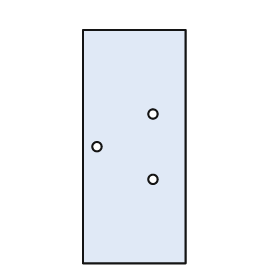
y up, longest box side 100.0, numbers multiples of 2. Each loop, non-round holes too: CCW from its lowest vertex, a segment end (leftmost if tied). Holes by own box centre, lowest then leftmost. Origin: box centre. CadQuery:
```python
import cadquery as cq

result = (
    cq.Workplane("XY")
    .moveTo(-22.0, -50.0)
    .lineTo(22.0, -50.0)
    .lineTo(22.0, 50.0)
    .lineTo(-22.0, 50.0)
    .close()
    .moveTo(8.0, -14.0)
    .circle(2.0)
    .moveTo(-16.0, 0.0)
    .circle(2.0)
    .moveTo(8.0, 14.0)
    .circle(2.0)
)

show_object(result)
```